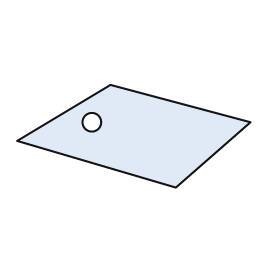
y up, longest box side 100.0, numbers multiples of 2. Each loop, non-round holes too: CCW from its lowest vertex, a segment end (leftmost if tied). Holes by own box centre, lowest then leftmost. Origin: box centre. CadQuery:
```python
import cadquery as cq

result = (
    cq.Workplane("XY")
    .moveTo(18.0, -22.0)
    .lineTo(50.0, 6.0)
    .lineTo(-10.0, 22.0)
    .lineTo(-50.0, -2.0)
    .close()
    .moveTo(-18.0, 6.0)
    .circle(4.0)
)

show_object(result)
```